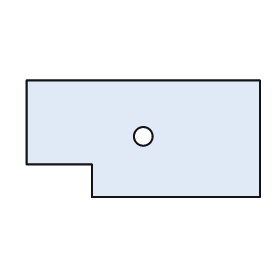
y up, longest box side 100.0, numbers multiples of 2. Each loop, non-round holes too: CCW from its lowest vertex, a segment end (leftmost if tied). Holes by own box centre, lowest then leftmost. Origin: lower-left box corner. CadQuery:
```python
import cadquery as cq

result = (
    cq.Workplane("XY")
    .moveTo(28.0, 0.0)
    .lineTo(100.0, 0.0)
    .lineTo(100.0, 50.0)
    .lineTo(0.0, 50.0)
    .lineTo(0.0, 14.0)
    .lineTo(28.0, 14.0)
    .close()
    .moveTo(50.0, 26.0)
    .circle(4.0)
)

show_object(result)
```